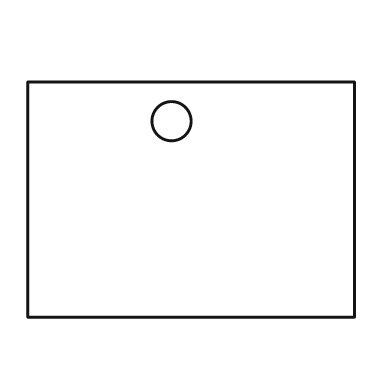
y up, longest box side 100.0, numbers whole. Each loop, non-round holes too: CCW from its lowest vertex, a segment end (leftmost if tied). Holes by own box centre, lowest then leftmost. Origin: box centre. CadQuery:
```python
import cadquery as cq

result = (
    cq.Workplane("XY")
    .moveTo(-50.0, -36.0)
    .lineTo(50.0, -36.0)
    .lineTo(50.0, 36.0)
    .lineTo(-50.0, 36.0)
    .close()
    .moveTo(-6.0, 24.0)
    .circle(6.0)
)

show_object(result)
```